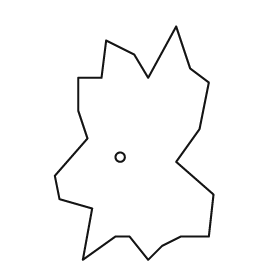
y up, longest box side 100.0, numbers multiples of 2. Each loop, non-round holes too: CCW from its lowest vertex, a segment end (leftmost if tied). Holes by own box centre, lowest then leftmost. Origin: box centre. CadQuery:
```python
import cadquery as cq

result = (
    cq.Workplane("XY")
    .moveTo(-22.0, -50.0)
    .lineTo(-8.0, -40.0)
    .lineTo(-2.0, -40.0)
    .lineTo(6.0, -50.0)
    .lineTo(12.0, -44.0)
    .lineTo(20.0, -40.0)
    .lineTo(32.0, -40.0)
    .lineTo(34.0, -22.0)
    .lineTo(18.0, -8.0)
    .lineTo(28.0, 6.0)
    .lineTo(32.0, 26.0)
    .lineTo(24.0, 32.0)
    .lineTo(18.0, 50.0)
    .lineTo(6.0, 28.0)
    .lineTo(0.0, 38.0)
    .lineTo(-12.0, 44.0)
    .lineTo(-14.0, 28.0)
    .lineTo(-24.0, 28.0)
    .lineTo(-24.0, 14.0)
    .lineTo(-20.0, 2.0)
    .lineTo(-34.0, -14.0)
    .lineTo(-32.0, -24.0)
    .lineTo(-18.0, -28.0)
    .close()
    .moveTo(-6.0, -6.0)
    .circle(2.0)
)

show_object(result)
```